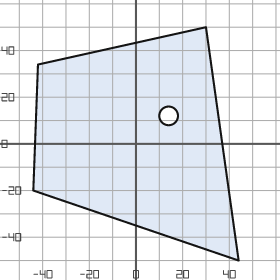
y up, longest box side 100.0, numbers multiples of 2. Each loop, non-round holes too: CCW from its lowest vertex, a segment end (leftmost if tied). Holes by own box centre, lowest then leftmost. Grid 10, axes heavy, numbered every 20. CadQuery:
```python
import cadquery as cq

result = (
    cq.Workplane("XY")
    .moveTo(44.0, -50.0)
    .lineTo(30.0, 50.0)
    .lineTo(-42.0, 34.0)
    .lineTo(-44.0, -20.0)
    .close()
    .moveTo(14.0, 12.0)
    .circle(4.0)
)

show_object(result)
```